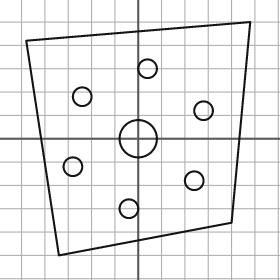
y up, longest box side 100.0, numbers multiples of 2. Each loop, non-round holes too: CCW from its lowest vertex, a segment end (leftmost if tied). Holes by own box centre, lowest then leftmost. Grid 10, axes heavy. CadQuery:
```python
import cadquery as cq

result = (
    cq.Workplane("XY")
    .moveTo(-34.0, -50.0)
    .lineTo(40.0, -36.0)
    .lineTo(48.0, 50.0)
    .lineTo(-48.0, 42.0)
    .close()
    .moveTo(-4.0, -30.0)
    .circle(4.0)
    .moveTo(24.0, -18.0)
    .circle(4.0)
    .moveTo(-28.0, -12.0)
    .circle(4.0)
    .moveTo(0.0, 0.0)
    .circle(8.0)
    .moveTo(28.0, 12.0)
    .circle(4.0)
    .moveTo(-24.0, 18.0)
    .circle(4.0)
    .moveTo(4.0, 30.0)
    .circle(4.0)
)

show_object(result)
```